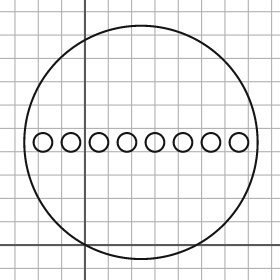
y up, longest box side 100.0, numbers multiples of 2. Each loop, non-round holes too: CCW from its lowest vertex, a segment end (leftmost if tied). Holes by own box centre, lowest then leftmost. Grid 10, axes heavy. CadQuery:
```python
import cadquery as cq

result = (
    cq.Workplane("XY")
    .moveTo(24.0, 44.0)
    .circle(50.0)
    .moveTo(-18.0, 44.0)
    .circle(4.0)
    .moveTo(-6.0, 44.0)
    .circle(4.0)
    .moveTo(6.0, 44.0)
    .circle(4.0)
    .moveTo(18.0, 44.0)
    .circle(4.0)
    .moveTo(30.0, 44.0)
    .circle(4.0)
    .moveTo(42.0, 44.0)
    .circle(4.0)
    .moveTo(54.0, 44.0)
    .circle(4.0)
    .moveTo(66.0, 44.0)
    .circle(4.0)
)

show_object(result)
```